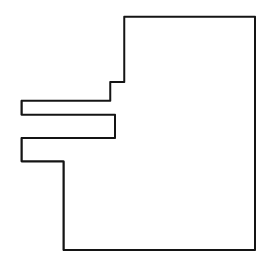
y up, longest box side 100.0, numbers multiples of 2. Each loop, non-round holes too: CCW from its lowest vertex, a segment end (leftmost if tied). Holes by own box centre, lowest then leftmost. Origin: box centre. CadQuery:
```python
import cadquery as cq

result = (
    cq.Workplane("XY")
    .moveTo(-32.0, -50.0)
    .lineTo(50.0, -50.0)
    .lineTo(50.0, 50.0)
    .lineTo(-6.0, 50.0)
    .lineTo(-6.0, 22.0)
    .lineTo(-12.0, 22.0)
    .lineTo(-12.0, 14.0)
    .lineTo(-50.0, 14.0)
    .lineTo(-50.0, 8.0)
    .lineTo(-10.0, 8.0)
    .lineTo(-10.0, -2.0)
    .lineTo(-50.0, -2.0)
    .lineTo(-50.0, -12.0)
    .lineTo(-32.0, -12.0)
    .close()
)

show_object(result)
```